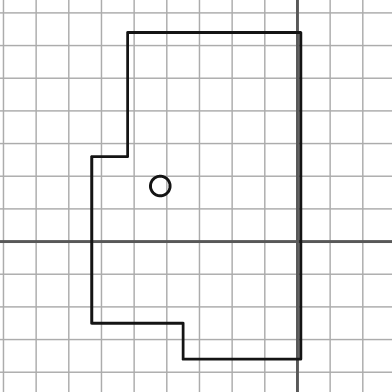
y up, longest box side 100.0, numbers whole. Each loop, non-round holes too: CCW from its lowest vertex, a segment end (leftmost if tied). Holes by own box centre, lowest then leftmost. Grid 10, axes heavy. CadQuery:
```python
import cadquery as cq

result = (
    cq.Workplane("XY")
    .moveTo(-35.0, -36.0)
    .lineTo(1.0, -36.0)
    .lineTo(1.0, 64.0)
    .lineTo(-52.0, 64.0)
    .lineTo(-52.0, 26.0)
    .lineTo(-63.0, 26.0)
    .lineTo(-63.0, -25.0)
    .lineTo(-35.0, -25.0)
    .close()
    .moveTo(-42.0, 17.0)
    .circle(3.0)
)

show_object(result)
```